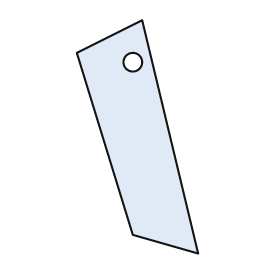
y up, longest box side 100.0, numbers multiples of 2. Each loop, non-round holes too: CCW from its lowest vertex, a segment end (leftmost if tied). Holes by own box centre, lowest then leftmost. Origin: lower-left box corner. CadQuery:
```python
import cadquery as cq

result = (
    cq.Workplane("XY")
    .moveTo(52.0, 0.0)
    .lineTo(28.0, 100.0)
    .lineTo(0.0, 86.0)
    .lineTo(24.0, 8.0)
    .close()
    .moveTo(24.0, 82.0)
    .circle(4.0)
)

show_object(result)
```